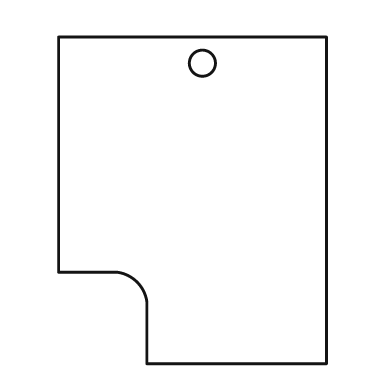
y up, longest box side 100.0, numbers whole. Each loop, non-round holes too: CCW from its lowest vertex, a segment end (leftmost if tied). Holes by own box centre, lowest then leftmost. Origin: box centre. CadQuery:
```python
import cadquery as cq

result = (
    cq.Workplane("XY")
    .moveTo(-14.0, -50.0)
    .lineTo(41.0, -50.0)
    .lineTo(41.0, 50.0)
    .lineTo(-41.0, 50.0)
    .lineTo(-41.0, -22.0)
    .lineTo(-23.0, -22.0)
    .threePointArc((-17.0, -25.0), (-14.0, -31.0))
    .close()
    .moveTo(3.0, 42.0)
    .circle(4.0)
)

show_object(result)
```